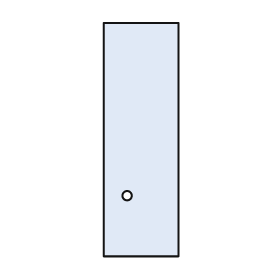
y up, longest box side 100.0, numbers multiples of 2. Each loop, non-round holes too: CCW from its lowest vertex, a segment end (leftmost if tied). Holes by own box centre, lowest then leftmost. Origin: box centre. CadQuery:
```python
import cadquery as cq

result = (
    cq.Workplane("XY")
    .moveTo(-16.0, -50.0)
    .lineTo(16.0, -50.0)
    .lineTo(16.0, 50.0)
    .lineTo(-16.0, 50.0)
    .close()
    .moveTo(-6.0, -24.0)
    .circle(2.0)
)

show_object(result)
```